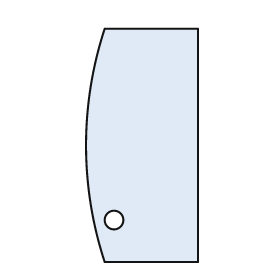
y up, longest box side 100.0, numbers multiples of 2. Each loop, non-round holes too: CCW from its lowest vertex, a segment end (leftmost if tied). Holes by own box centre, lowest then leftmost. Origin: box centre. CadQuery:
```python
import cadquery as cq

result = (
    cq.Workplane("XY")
    .moveTo(-16.0, -50.0)
    .lineTo(24.0, -50.0)
    .lineTo(24.0, 50.0)
    .lineTo(-16.0, 50.0)
    .threePointArc((-24.0, 0.0), (-16.0, -50.0))
    .close()
    .moveTo(-12.0, -32.0)
    .circle(4.0)
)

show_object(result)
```